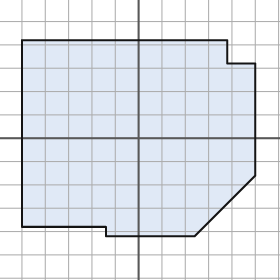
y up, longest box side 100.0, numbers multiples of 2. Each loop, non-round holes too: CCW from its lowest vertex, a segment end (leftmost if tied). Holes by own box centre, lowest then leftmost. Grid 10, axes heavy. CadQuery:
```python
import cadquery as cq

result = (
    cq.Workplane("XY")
    .moveTo(-14.0, -42.0)
    .lineTo(24.0, -42.0)
    .lineTo(50.0, -16.0)
    .lineTo(50.0, 32.0)
    .lineTo(38.0, 32.0)
    .lineTo(38.0, 42.0)
    .lineTo(-50.0, 42.0)
    .lineTo(-50.0, -38.0)
    .lineTo(-14.0, -38.0)
    .close()
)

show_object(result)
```